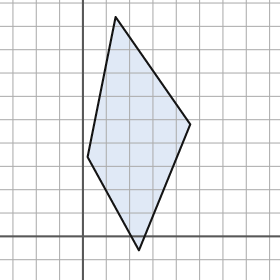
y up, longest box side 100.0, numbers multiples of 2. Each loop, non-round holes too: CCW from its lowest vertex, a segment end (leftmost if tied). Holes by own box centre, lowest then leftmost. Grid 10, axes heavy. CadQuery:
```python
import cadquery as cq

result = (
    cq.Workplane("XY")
    .moveTo(24.0, -6.0)
    .lineTo(46.0, 48.0)
    .lineTo(14.0, 94.0)
    .lineTo(2.0, 34.0)
    .close()
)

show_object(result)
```